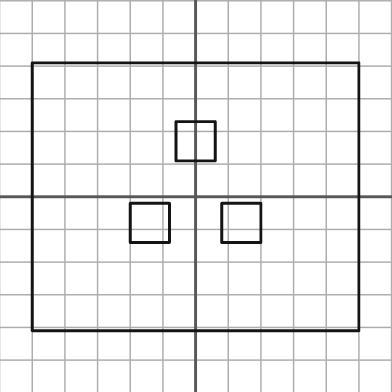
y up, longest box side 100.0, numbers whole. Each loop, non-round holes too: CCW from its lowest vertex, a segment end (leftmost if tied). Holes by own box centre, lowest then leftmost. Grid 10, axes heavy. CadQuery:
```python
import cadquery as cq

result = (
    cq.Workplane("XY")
    .moveTo(-50.0, -41.0)
    .lineTo(50.0, -41.0)
    .lineTo(50.0, 41.0)
    .lineTo(-50.0, 41.0)
    .close()
    .moveTo(-20.0, -14.0)
    .lineTo(-8.0, -14.0)
    .lineTo(-8.0, -2.0)
    .lineTo(-20.0, -2.0)
    .close()
    .moveTo(8.0, -14.0)
    .lineTo(20.0, -14.0)
    .lineTo(20.0, -2.0)
    .lineTo(8.0, -2.0)
    .close()
    .moveTo(-6.0, 11.0)
    .lineTo(6.0, 11.0)
    .lineTo(6.0, 23.0)
    .lineTo(-6.0, 23.0)
    .close()
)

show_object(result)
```